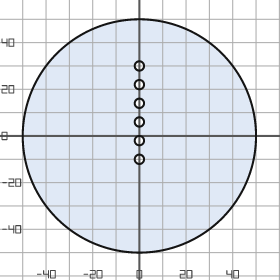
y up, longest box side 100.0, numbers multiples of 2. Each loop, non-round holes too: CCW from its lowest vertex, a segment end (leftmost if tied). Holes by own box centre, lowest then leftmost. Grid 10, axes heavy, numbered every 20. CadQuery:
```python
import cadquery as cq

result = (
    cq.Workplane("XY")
    .moveTo(0.0, 0.0)
    .circle(50.0)
    .moveTo(0.0, -10.0)
    .circle(2.0)
    .moveTo(0.0, -2.0)
    .circle(2.0)
    .moveTo(0.0, 6.0)
    .circle(2.0)
    .moveTo(0.0, 14.0)
    .circle(2.0)
    .moveTo(0.0, 22.0)
    .circle(2.0)
    .moveTo(0.0, 30.0)
    .circle(2.0)
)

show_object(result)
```